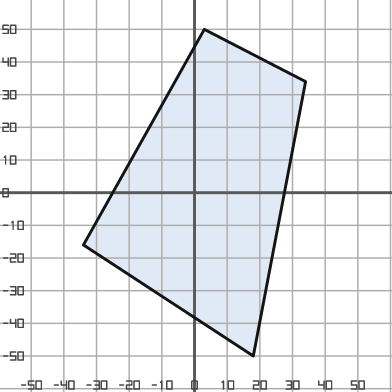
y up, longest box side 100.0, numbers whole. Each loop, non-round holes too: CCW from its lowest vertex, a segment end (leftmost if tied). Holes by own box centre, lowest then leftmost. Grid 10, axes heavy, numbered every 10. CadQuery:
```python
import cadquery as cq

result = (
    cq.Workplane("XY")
    .moveTo(18.0, -50.0)
    .lineTo(34.0, 34.0)
    .lineTo(3.0, 50.0)
    .lineTo(-34.0, -16.0)
    .close()
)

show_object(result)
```